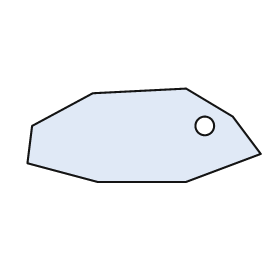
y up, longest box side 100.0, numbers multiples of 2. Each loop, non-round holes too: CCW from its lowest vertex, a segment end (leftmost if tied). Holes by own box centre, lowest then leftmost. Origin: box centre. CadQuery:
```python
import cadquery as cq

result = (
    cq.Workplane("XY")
    .moveTo(-20.0, -20.0)
    .lineTo(18.0, -20.0)
    .lineTo(50.0, -8.0)
    .lineTo(38.0, 8.0)
    .lineTo(18.0, 20.0)
    .lineTo(-22.0, 18.0)
    .lineTo(-48.0, 4.0)
    .lineTo(-50.0, -12.0)
    .close()
    .moveTo(26.0, 4.0)
    .circle(4.0)
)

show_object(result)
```